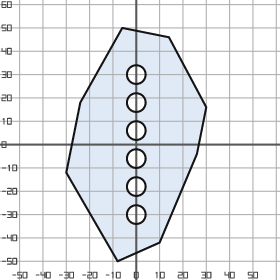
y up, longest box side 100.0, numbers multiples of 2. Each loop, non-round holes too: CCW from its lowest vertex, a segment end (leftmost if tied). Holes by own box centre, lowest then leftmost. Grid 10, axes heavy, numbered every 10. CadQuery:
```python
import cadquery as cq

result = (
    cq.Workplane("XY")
    .moveTo(-8.0, -50.0)
    .lineTo(10.0, -42.0)
    .lineTo(26.0, -4.0)
    .lineTo(30.0, 16.0)
    .lineTo(14.0, 46.0)
    .lineTo(-6.0, 50.0)
    .lineTo(-24.0, 18.0)
    .lineTo(-30.0, -12.0)
    .close()
    .moveTo(0.0, -30.0)
    .circle(4.0)
    .moveTo(0.0, -18.0)
    .circle(4.0)
    .moveTo(0.0, -6.0)
    .circle(4.0)
    .moveTo(0.0, 6.0)
    .circle(4.0)
    .moveTo(0.0, 18.0)
    .circle(4.0)
    .moveTo(0.0, 30.0)
    .circle(4.0)
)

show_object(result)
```